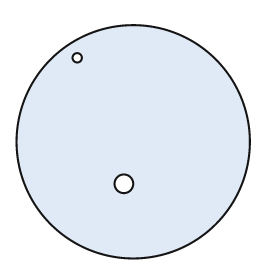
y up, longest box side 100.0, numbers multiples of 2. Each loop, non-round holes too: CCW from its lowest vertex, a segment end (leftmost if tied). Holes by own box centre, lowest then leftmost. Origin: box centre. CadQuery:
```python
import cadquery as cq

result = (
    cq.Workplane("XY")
    .moveTo(0.0, 0.0)
    .circle(50.0)
    .moveTo(-4.0, -18.0)
    .circle(4.0)
    .moveTo(-24.0, 36.0)
    .circle(2.0)
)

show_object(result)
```